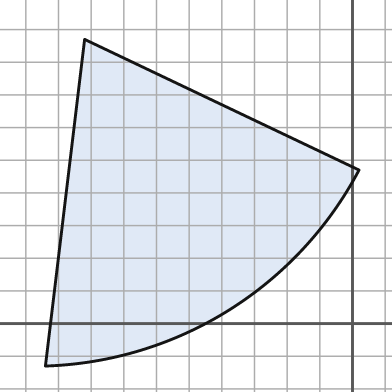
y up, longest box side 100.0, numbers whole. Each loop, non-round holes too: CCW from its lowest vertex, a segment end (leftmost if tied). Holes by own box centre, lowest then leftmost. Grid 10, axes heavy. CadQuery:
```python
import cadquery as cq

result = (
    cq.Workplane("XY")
    .moveTo(-94.0, -13.0)
    .threePointArc((-38.0, 4.0), (2.0, 47.0))
    .lineTo(-82.0, 87.0)
    .close()
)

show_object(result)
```